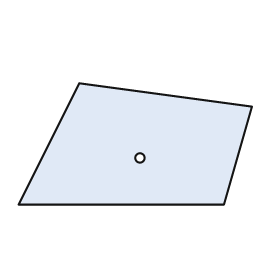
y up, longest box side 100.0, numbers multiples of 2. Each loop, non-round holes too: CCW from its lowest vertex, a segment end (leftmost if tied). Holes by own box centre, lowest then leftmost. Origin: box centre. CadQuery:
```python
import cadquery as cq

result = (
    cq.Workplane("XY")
    .moveTo(-50.0, -26.0)
    .lineTo(38.0, -26.0)
    .lineTo(50.0, 16.0)
    .lineTo(-24.0, 26.0)
    .close()
    .moveTo(2.0, -6.0)
    .circle(2.0)
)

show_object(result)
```